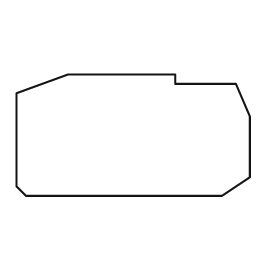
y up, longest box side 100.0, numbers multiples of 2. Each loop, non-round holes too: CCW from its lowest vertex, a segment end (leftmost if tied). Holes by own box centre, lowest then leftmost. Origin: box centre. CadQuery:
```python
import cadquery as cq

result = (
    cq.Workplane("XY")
    .moveTo(-46.0, -26.0)
    .lineTo(38.0, -26.0)
    .lineTo(50.0, -18.0)
    .lineTo(50.0, 8.0)
    .lineTo(44.0, 22.0)
    .lineTo(18.0, 22.0)
    .lineTo(18.0, 26.0)
    .lineTo(-28.0, 26.0)
    .lineTo(-50.0, 18.0)
    .lineTo(-50.0, -22.0)
    .close()
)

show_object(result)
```